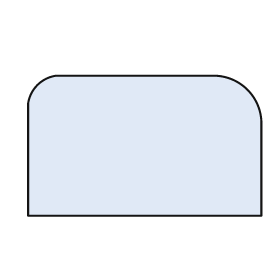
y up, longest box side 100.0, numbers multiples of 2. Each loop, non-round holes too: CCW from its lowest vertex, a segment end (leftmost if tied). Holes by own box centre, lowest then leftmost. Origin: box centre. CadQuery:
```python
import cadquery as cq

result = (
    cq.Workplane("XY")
    .moveTo(-50.0, -30.0)
    .lineTo(50.0, -30.0)
    .lineTo(50.0, 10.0)
    .threePointArc((44.0, 24.0), (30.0, 30.0))
    .lineTo(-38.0, 30.0)
    .threePointArc((-46.0, 26.0), (-50.0, 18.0))
    .close()
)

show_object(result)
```